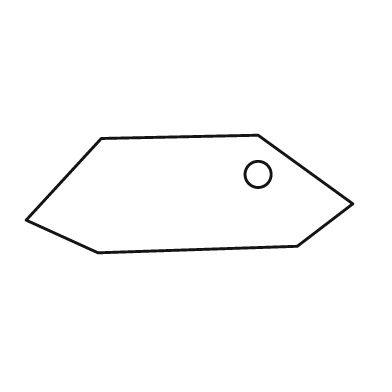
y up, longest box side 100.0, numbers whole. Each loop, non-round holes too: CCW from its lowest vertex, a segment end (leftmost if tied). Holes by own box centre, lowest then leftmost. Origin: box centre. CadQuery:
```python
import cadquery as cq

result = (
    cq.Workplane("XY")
    .moveTo(-28.0, -18.0)
    .lineTo(33.0, -16.0)
    .lineTo(50.0, -3.0)
    .lineTo(21.0, 18.0)
    .lineTo(-27.0, 17.0)
    .lineTo(-50.0, -8.0)
    .close()
    .moveTo(21.0, 6.0)
    .circle(4.0)
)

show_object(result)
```